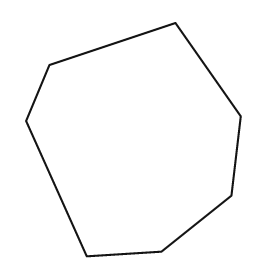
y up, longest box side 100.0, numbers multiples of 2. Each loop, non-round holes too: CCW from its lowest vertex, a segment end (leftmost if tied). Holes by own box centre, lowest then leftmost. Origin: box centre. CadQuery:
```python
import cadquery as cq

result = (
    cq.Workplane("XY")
    .moveTo(-20.0, -50.0)
    .lineTo(12.0, -48.0)
    .lineTo(42.0, -24.0)
    .lineTo(46.0, 10.0)
    .lineTo(18.0, 50.0)
    .lineTo(-36.0, 32.0)
    .lineTo(-46.0, 8.0)
    .close()
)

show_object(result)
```